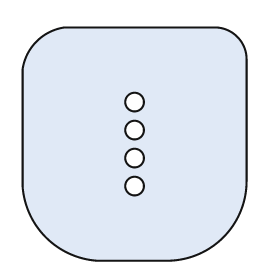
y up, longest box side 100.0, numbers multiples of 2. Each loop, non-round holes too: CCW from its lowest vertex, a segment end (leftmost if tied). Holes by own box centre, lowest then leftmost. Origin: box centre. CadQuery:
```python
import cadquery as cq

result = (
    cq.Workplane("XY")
    .moveTo(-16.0, -50.0)
    .lineTo(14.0, -50.0)
    .threePointArc((38.0, -40.0), (48.0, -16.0))
    .lineTo(48.0, 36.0)
    .threePointArc((44.0, 46.0), (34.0, 50.0))
    .lineTo(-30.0, 50.0)
    .threePointArc((-42.0, 44.0), (-48.0, 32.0))
    .lineTo(-48.0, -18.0)
    .threePointArc((-38.0, -40.0), (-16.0, -50.0))
    .close()
    .moveTo(0.0, -18.0)
    .circle(4.0)
    .moveTo(0.0, -6.0)
    .circle(4.0)
    .moveTo(0.0, 6.0)
    .circle(4.0)
    .moveTo(0.0, 18.0)
    .circle(4.0)
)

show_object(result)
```